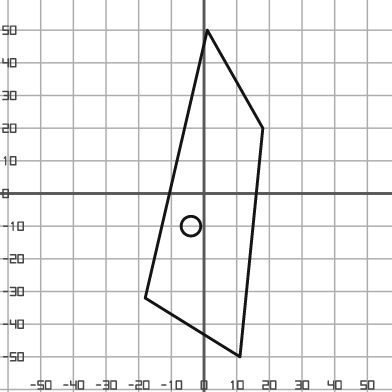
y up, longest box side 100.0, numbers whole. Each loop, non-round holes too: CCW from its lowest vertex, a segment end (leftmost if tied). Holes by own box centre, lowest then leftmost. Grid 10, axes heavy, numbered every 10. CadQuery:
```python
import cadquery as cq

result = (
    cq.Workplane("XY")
    .moveTo(11.0, -50.0)
    .lineTo(18.0, 20.0)
    .lineTo(1.0, 50.0)
    .lineTo(-18.0, -32.0)
    .close()
    .moveTo(-4.0, -10.0)
    .circle(3.0)
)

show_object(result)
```